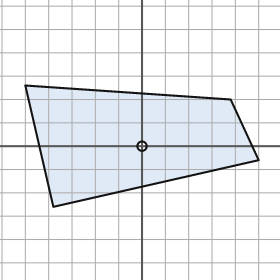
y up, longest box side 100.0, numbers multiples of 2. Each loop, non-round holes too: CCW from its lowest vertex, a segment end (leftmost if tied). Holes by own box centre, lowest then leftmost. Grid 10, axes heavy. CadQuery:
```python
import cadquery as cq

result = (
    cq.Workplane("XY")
    .moveTo(-38.0, -26.0)
    .lineTo(50.0, -6.0)
    .lineTo(38.0, 20.0)
    .lineTo(-50.0, 26.0)
    .close()
    .moveTo(0.0, 0.0)
    .circle(2.0)
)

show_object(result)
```